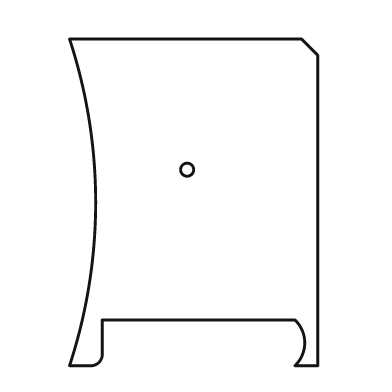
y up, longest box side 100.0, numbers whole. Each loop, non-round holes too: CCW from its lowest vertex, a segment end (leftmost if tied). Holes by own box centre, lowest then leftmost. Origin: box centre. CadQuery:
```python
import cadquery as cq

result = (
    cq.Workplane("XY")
    .moveTo(-38.0, -50.0)
    .lineTo(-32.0, -50.0)
    .threePointArc((-29.0, -49.0), (-28.0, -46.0))
    .lineTo(-28.0, -36.0)
    .lineTo(31.0, -36.0)
    .threePointArc((34.0, -43.0), (31.0, -50.0))
    .lineTo(38.0, -50.0)
    .lineTo(38.0, 45.0)
    .lineTo(33.0, 50.0)
    .lineTo(-38.0, 50.0)
    .threePointArc((-30.0, 0.0), (-38.0, -50.0))
    .close()
    .moveTo(-2.0, 10.0)
    .circle(2.0)
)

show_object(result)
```